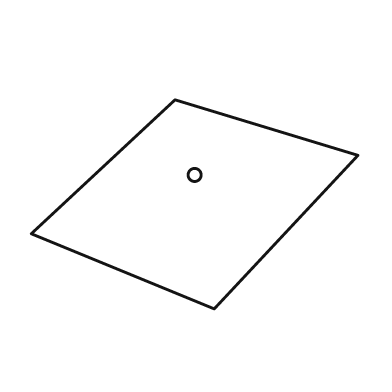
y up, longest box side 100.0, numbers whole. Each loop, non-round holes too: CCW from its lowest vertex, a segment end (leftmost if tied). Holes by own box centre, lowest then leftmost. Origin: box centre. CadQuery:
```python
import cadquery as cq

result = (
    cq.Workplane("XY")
    .moveTo(6.0, -32.0)
    .lineTo(50.0, 15.0)
    .lineTo(-6.0, 32.0)
    .lineTo(-50.0, -9.0)
    .close()
    .moveTo(0.0, 9.0)
    .circle(2.0)
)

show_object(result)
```